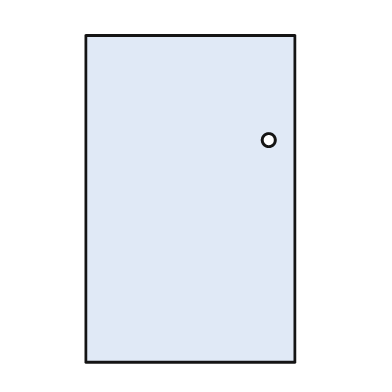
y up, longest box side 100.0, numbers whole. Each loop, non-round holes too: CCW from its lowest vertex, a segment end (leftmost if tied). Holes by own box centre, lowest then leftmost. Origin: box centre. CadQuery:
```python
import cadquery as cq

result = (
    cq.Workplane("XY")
    .moveTo(-32.0, -50.0)
    .lineTo(32.0, -50.0)
    .lineTo(32.0, 50.0)
    .lineTo(-32.0, 50.0)
    .close()
    .moveTo(24.0, 18.0)
    .circle(2.0)
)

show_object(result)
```